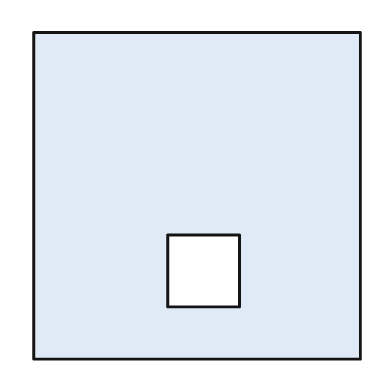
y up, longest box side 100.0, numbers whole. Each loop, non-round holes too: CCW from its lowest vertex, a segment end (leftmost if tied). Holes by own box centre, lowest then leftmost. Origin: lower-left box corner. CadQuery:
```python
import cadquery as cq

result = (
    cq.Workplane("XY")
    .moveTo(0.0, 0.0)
    .lineTo(100.0, 0.0)
    .lineTo(100.0, 100.0)
    .lineTo(0.0, 100.0)
    .close()
    .moveTo(41.0, 16.0)
    .lineTo(63.0, 16.0)
    .lineTo(63.0, 38.0)
    .lineTo(41.0, 38.0)
    .close()
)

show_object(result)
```